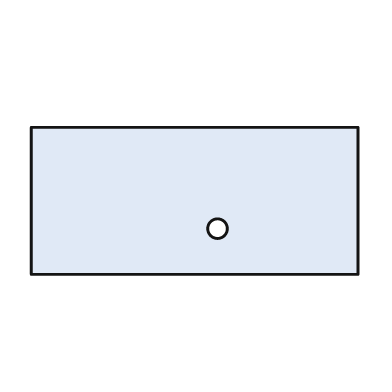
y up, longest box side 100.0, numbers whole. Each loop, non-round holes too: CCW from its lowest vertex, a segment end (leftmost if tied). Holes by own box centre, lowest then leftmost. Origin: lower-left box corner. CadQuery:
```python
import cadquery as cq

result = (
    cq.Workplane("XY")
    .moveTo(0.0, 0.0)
    .lineTo(100.0, 0.0)
    .lineTo(100.0, 45.0)
    .lineTo(0.0, 45.0)
    .close()
    .moveTo(57.0, 14.0)
    .circle(3.0)
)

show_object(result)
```